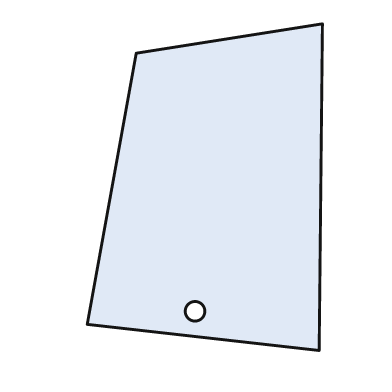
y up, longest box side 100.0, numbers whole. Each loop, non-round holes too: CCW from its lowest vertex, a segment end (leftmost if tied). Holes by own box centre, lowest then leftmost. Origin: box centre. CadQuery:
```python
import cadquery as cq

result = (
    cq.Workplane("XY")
    .moveTo(35.0, -50.0)
    .lineTo(36.0, 50.0)
    .lineTo(-21.0, 41.0)
    .lineTo(-36.0, -42.0)
    .close()
    .moveTo(-3.0, -38.0)
    .circle(3.0)
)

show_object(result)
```